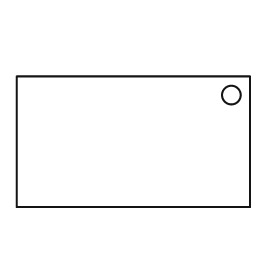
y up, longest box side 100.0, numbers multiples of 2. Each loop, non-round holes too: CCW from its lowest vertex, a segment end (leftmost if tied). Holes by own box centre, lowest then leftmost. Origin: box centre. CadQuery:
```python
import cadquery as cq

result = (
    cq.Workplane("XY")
    .moveTo(-50.0, -28.0)
    .lineTo(50.0, -28.0)
    .lineTo(50.0, 28.0)
    .lineTo(-50.0, 28.0)
    .close()
    .moveTo(42.0, 20.0)
    .circle(4.0)
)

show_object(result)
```